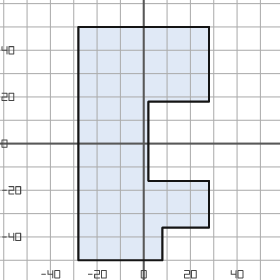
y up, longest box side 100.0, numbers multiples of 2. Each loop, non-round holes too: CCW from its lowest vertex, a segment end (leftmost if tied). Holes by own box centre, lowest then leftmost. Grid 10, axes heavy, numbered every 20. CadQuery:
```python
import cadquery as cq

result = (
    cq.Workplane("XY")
    .moveTo(-28.0, -50.0)
    .lineTo(8.0, -50.0)
    .lineTo(8.0, -36.0)
    .lineTo(28.0, -36.0)
    .lineTo(28.0, -16.0)
    .lineTo(2.0, -16.0)
    .lineTo(2.0, 18.0)
    .lineTo(28.0, 18.0)
    .lineTo(28.0, 50.0)
    .lineTo(-28.0, 50.0)
    .close()
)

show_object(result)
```